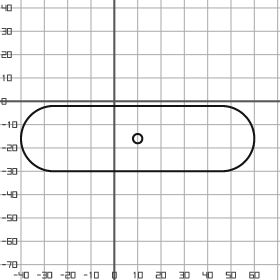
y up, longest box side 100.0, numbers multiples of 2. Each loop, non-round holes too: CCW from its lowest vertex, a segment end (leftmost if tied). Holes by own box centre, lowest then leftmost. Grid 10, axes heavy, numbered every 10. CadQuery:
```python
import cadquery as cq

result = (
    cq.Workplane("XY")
    .moveTo(-26.0, -30.0)
    .lineTo(46.0, -30.0)
    .threePointArc((60.0, -16.0), (46.0, -2.0))
    .lineTo(-26.0, -2.0)
    .threePointArc((-40.0, -16.0), (-26.0, -30.0))
    .close()
    .moveTo(10.0, -16.0)
    .circle(2.0)
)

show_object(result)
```